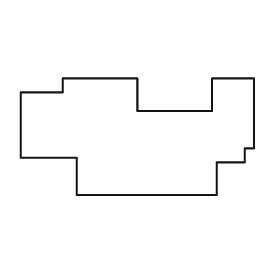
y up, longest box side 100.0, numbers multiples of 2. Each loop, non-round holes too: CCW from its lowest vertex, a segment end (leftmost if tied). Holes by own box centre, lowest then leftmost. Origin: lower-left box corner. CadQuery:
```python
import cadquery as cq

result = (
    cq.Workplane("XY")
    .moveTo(24.0, 0.0)
    .lineTo(84.0, 0.0)
    .lineTo(84.0, 14.0)
    .lineTo(96.0, 14.0)
    .lineTo(96.0, 20.0)
    .lineTo(100.0, 20.0)
    .lineTo(100.0, 50.0)
    .lineTo(82.0, 50.0)
    .lineTo(82.0, 36.0)
    .lineTo(50.0, 36.0)
    .lineTo(50.0, 50.0)
    .lineTo(18.0, 50.0)
    .lineTo(18.0, 44.0)
    .lineTo(0.0, 44.0)
    .lineTo(0.0, 16.0)
    .lineTo(24.0, 16.0)
    .close()
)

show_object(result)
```